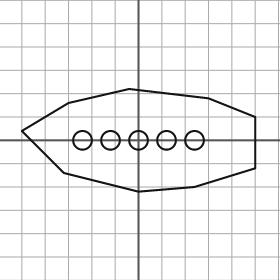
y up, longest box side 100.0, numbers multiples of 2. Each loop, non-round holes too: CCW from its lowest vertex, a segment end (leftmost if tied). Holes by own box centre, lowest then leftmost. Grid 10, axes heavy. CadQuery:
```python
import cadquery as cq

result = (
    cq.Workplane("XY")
    .moveTo(0.0, -22.0)
    .lineTo(24.0, -20.0)
    .lineTo(50.0, -12.0)
    .lineTo(50.0, 10.0)
    .lineTo(30.0, 18.0)
    .lineTo(-4.0, 22.0)
    .lineTo(-30.0, 16.0)
    .lineTo(-50.0, 4.0)
    .lineTo(-32.0, -14.0)
    .close()
    .moveTo(-24.0, 0.0)
    .circle(4.0)
    .moveTo(-12.0, 0.0)
    .circle(4.0)
    .moveTo(0.0, 0.0)
    .circle(4.0)
    .moveTo(12.0, 0.0)
    .circle(4.0)
    .moveTo(24.0, 0.0)
    .circle(4.0)
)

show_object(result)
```